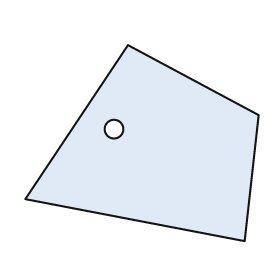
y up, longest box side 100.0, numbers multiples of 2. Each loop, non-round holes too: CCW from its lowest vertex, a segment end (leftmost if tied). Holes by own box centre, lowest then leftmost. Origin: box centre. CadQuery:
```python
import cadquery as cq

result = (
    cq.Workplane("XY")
    .moveTo(44.0, -42.0)
    .lineTo(50.0, 12.0)
    .lineTo(-6.0, 42.0)
    .lineTo(-50.0, -24.0)
    .close()
    .moveTo(-12.0, 6.0)
    .circle(4.0)
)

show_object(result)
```